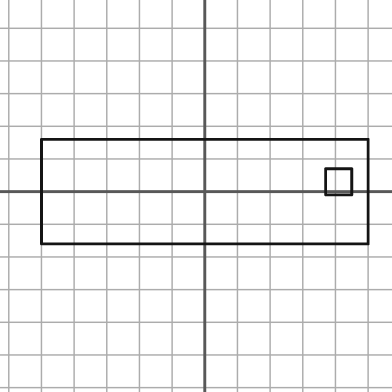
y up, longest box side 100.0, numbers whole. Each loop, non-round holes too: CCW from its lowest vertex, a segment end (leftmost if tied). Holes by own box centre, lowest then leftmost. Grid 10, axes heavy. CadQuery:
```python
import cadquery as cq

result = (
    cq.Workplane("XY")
    .moveTo(-50.0, -16.0)
    .lineTo(50.0, -16.0)
    .lineTo(50.0, 16.0)
    .lineTo(-50.0, 16.0)
    .close()
    .moveTo(37.0, -1.0)
    .lineTo(45.0, -1.0)
    .lineTo(45.0, 7.0)
    .lineTo(37.0, 7.0)
    .close()
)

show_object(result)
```